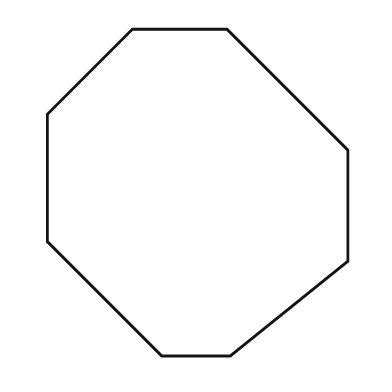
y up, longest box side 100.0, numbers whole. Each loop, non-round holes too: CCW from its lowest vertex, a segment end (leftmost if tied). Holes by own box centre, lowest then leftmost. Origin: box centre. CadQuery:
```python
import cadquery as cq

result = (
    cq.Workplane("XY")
    .moveTo(-11.0, -50.0)
    .lineTo(10.0, -50.0)
    .lineTo(46.0, -21.0)
    .lineTo(46.0, 13.0)
    .lineTo(9.0, 50.0)
    .lineTo(-20.0, 50.0)
    .lineTo(-46.0, 24.0)
    .lineTo(-46.0, -15.0)
    .close()
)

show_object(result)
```